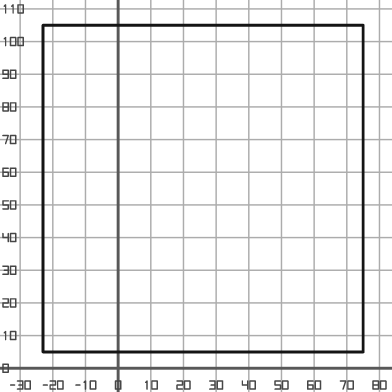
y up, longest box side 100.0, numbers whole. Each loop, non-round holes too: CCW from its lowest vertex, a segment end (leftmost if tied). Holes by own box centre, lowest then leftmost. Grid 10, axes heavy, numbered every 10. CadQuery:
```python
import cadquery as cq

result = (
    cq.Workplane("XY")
    .moveTo(-23.0, 5.0)
    .lineTo(75.0, 5.0)
    .lineTo(75.0, 105.0)
    .lineTo(-23.0, 105.0)
    .close()
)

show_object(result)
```